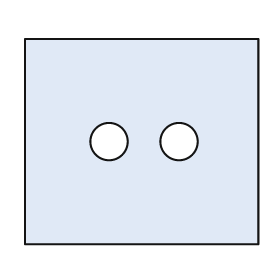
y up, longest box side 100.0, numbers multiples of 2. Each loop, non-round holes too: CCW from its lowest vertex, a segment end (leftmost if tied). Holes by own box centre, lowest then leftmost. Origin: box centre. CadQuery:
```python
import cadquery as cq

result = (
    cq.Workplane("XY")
    .moveTo(-50.0, -44.0)
    .lineTo(50.0, -44.0)
    .lineTo(50.0, 44.0)
    .lineTo(-50.0, 44.0)
    .close()
    .moveTo(-14.0, 0.0)
    .circle(8.0)
    .moveTo(16.0, 0.0)
    .circle(8.0)
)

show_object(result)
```